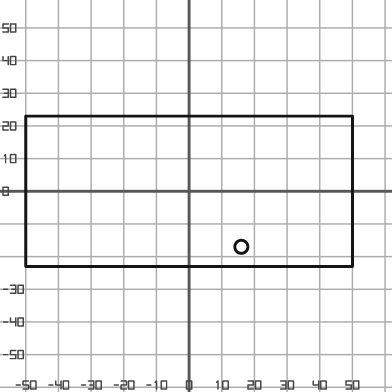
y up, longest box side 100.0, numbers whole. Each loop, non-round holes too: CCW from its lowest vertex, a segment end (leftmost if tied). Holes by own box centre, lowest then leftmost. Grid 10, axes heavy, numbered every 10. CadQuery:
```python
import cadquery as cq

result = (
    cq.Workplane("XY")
    .moveTo(-50.0, -23.0)
    .lineTo(50.0, -23.0)
    .lineTo(50.0, 23.0)
    .lineTo(-50.0, 23.0)
    .close()
    .moveTo(16.0, -17.0)
    .circle(2.0)
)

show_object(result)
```